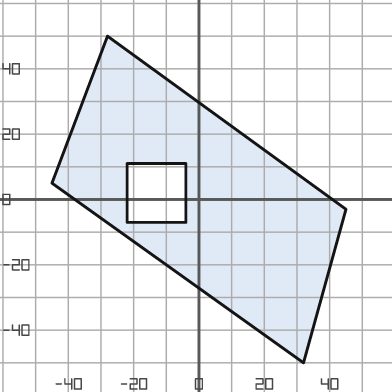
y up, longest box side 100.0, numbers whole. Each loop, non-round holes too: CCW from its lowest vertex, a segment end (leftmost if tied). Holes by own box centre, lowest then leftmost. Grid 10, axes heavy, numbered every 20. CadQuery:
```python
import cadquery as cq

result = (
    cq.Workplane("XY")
    .moveTo(32.0, -50.0)
    .lineTo(45.0, -3.0)
    .lineTo(-28.0, 50.0)
    .lineTo(-45.0, 5.0)
    .close()
    .moveTo(-22.0, -7.0)
    .lineTo(-4.0, -7.0)
    .lineTo(-4.0, 11.0)
    .lineTo(-22.0, 11.0)
    .close()
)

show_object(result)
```